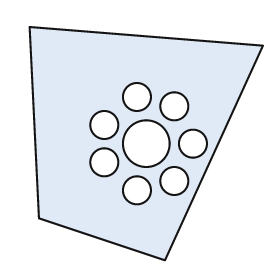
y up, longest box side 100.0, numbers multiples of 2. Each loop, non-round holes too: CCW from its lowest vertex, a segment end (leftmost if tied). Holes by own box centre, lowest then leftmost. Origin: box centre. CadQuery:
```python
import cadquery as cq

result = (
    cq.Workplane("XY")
    .moveTo(8.0, -50.0)
    .lineTo(50.0, 42.0)
    .lineTo(-50.0, 50.0)
    .lineTo(-46.0, -32.0)
    .close()
    .moveTo(-4.0, -20.0)
    .circle(6.0)
    .moveTo(12.0, -16.0)
    .circle(6.0)
    .moveTo(-18.0, -8.0)
    .circle(6.0)
    .moveTo(0.0, 0.0)
    .circle(10.0)
    .moveTo(20.0, 0.0)
    .circle(6.0)
    .moveTo(-18.0, 8.0)
    .circle(6.0)
    .moveTo(12.0, 16.0)
    .circle(6.0)
    .moveTo(-4.0, 20.0)
    .circle(6.0)
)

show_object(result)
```